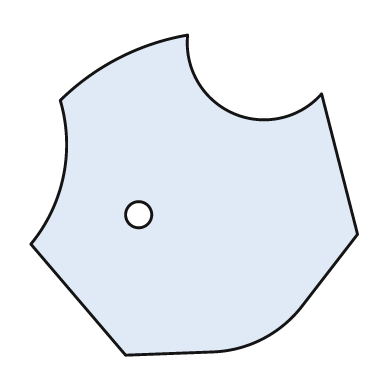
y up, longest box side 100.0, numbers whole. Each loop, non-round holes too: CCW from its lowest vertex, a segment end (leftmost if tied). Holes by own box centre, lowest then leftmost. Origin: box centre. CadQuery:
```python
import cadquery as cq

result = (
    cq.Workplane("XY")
    .moveTo(-21.0, -49.0)
    .lineTo(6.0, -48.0)
    .threePointArc((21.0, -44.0), (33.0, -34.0))
    .lineTo(50.0, -12.0)
    .lineTo(39.0, 31.0)
    .threePointArc((12.0, 25.0), (-2.0, 49.0))
    .threePointArc((-23.0, 42.0), (-41.0, 29.0))
    .threePointArc((-40.0, 6.0), (-50.0, -15.0))
    .close()
    .moveTo(-17.0, -6.0)
    .circle(4.0)
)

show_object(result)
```